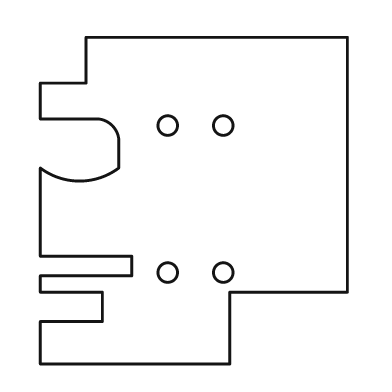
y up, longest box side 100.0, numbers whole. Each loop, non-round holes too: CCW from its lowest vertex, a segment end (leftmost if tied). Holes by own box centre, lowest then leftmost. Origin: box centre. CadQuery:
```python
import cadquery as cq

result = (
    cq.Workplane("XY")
    .moveTo(-47.0, -50.0)
    .lineTo(11.0, -50.0)
    .lineTo(11.0, -28.0)
    .lineTo(47.0, -28.0)
    .lineTo(47.0, 50.0)
    .lineTo(-33.0, 50.0)
    .lineTo(-33.0, 36.0)
    .lineTo(-47.0, 36.0)
    .lineTo(-47.0, 25.0)
    .lineTo(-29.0, 25.0)
    .threePointArc((-25.0, 23.0), (-23.0, 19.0))
    .lineTo(-23.0, 10.0)
    .threePointArc((-35.0, 6.0), (-47.0, 10.0))
    .lineTo(-47.0, -17.0)
    .lineTo(-19.0, -17.0)
    .lineTo(-19.0, -23.0)
    .lineTo(-47.0, -23.0)
    .lineTo(-47.0, -28.0)
    .lineTo(-28.0, -28.0)
    .lineTo(-28.0, -37.0)
    .lineTo(-47.0, -37.0)
    .close()
    .moveTo(-8.0, -22.0)
    .circle(3.0)
    .moveTo(9.0, -22.0)
    .circle(3.0)
    .moveTo(-8.0, 23.0)
    .circle(3.0)
    .moveTo(9.0, 23.0)
    .circle(3.0)
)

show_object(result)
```